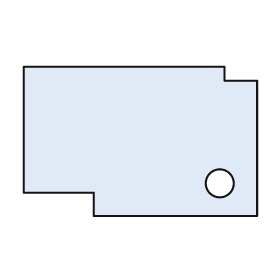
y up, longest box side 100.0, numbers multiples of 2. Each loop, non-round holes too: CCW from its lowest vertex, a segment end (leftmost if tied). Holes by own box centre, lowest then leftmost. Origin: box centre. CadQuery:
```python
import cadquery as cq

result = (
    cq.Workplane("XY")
    .moveTo(-20.0, -32.0)
    .lineTo(50.0, -32.0)
    .lineTo(50.0, 26.0)
    .lineTo(36.0, 26.0)
    .lineTo(36.0, 32.0)
    .lineTo(-50.0, 32.0)
    .lineTo(-50.0, -22.0)
    .lineTo(-20.0, -22.0)
    .close()
    .moveTo(34.0, -18.0)
    .circle(6.0)
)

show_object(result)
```